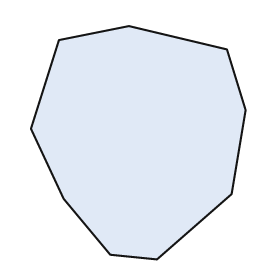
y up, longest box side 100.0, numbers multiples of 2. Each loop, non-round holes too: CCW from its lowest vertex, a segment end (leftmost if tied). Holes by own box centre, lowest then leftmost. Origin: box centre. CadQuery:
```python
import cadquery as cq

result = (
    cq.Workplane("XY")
    .moveTo(8.0, -50.0)
    .lineTo(40.0, -22.0)
    .lineTo(46.0, 14.0)
    .lineTo(38.0, 40.0)
    .lineTo(-4.0, 50.0)
    .lineTo(-34.0, 44.0)
    .lineTo(-46.0, 6.0)
    .lineTo(-32.0, -24.0)
    .lineTo(-12.0, -48.0)
    .close()
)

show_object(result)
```